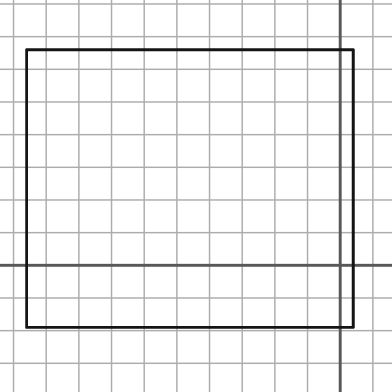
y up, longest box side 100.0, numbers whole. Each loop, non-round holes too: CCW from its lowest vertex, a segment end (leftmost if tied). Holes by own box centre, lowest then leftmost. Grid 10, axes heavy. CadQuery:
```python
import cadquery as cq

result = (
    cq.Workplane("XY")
    .moveTo(-96.0, -19.0)
    .lineTo(4.0, -19.0)
    .lineTo(4.0, 66.0)
    .lineTo(-96.0, 66.0)
    .close()
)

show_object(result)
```